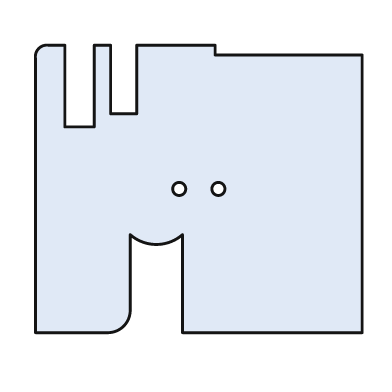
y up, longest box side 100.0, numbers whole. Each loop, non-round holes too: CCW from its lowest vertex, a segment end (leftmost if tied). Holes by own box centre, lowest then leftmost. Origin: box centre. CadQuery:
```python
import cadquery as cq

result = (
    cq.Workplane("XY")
    .moveTo(-50.0, -44.0)
    .lineTo(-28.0, -44.0)
    .threePointArc((-23.0, -42.0), (-21.0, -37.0))
    .lineTo(-21.0, -14.0)
    .threePointArc((-13.0, -17.0), (-5.0, -14.0))
    .lineTo(-5.0, -44.0)
    .lineTo(50.0, -44.0)
    .lineTo(50.0, 41.0)
    .lineTo(5.0, 41.0)
    .lineTo(5.0, 44.0)
    .lineTo(-19.0, 44.0)
    .lineTo(-19.0, 23.0)
    .lineTo(-27.0, 23.0)
    .lineTo(-27.0, 44.0)
    .lineTo(-32.0, 44.0)
    .lineTo(-32.0, 19.0)
    .lineTo(-41.0, 19.0)
    .lineTo(-41.0, 44.0)
    .lineTo(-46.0, 44.0)
    .threePointArc((-49.0, 43.0), (-50.0, 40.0))
    .close()
    .moveTo(-6.0, 0.0)
    .circle(2.0)
    .moveTo(6.0, 0.0)
    .circle(2.0)
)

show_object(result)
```